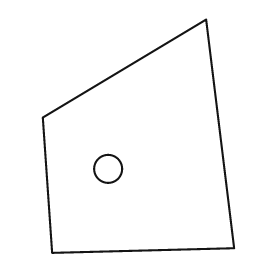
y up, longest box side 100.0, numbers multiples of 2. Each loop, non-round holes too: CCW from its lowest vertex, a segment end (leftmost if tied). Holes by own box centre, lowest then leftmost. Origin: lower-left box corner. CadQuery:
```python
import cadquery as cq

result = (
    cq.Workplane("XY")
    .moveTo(4.0, 0.0)
    .lineTo(82.0, 2.0)
    .lineTo(70.0, 100.0)
    .lineTo(0.0, 58.0)
    .close()
    .moveTo(28.0, 36.0)
    .circle(6.0)
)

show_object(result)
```